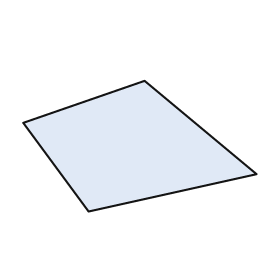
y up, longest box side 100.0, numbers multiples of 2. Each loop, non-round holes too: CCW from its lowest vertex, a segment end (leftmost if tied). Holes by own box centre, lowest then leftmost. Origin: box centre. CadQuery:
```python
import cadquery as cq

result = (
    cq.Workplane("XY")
    .moveTo(-22.0, -28.0)
    .lineTo(50.0, -12.0)
    .lineTo(2.0, 28.0)
    .lineTo(-50.0, 10.0)
    .close()
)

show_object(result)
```